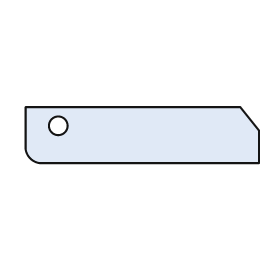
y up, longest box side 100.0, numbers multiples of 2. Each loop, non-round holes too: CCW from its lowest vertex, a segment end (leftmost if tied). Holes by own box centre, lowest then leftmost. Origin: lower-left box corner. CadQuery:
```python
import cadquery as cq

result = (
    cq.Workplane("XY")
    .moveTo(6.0, 0.0)
    .lineTo(100.0, 0.0)
    .lineTo(100.0, 14.0)
    .lineTo(92.0, 24.0)
    .lineTo(0.0, 24.0)
    .lineTo(0.0, 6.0)
    .threePointArc((2.0, 2.0), (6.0, 0.0))
    .close()
    .moveTo(14.0, 16.0)
    .circle(4.0)
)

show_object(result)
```